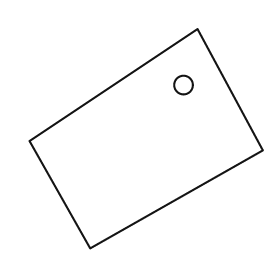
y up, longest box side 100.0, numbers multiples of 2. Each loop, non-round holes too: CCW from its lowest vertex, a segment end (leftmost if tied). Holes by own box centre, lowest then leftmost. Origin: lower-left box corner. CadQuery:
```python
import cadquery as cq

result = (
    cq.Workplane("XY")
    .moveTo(26.0, 0.0)
    .lineTo(100.0, 42.0)
    .lineTo(72.0, 94.0)
    .lineTo(0.0, 46.0)
    .close()
    .moveTo(66.0, 70.0)
    .circle(4.0)
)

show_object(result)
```